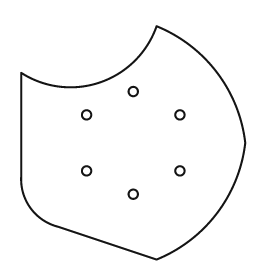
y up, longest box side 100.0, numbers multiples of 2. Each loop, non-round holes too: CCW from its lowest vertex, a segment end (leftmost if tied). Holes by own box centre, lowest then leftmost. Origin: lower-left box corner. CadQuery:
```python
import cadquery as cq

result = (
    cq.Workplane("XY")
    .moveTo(58.0, 0.0)
    .threePointArc((84.0, 20.0), (96.0, 50.0))
    .threePointArc((84.0, 80.0), (58.0, 100.0))
    .threePointArc((34.0, 76.0), (0.0, 80.0))
    .lineTo(0.0, 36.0)
    .threePointArc((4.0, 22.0), (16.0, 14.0))
    .close()
    .moveTo(48.0, 28.0)
    .circle(2.0)
    .moveTo(28.0, 38.0)
    .circle(2.0)
    .moveTo(68.0, 38.0)
    .circle(2.0)
    .moveTo(28.0, 62.0)
    .circle(2.0)
    .moveTo(68.0, 62.0)
    .circle(2.0)
    .moveTo(48.0, 72.0)
    .circle(2.0)
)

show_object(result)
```